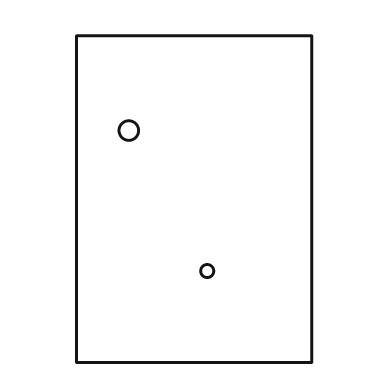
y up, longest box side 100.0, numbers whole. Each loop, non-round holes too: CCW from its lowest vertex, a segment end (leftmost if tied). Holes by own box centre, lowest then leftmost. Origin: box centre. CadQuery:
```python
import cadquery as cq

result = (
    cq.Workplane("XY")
    .moveTo(-36.0, -50.0)
    .lineTo(36.0, -50.0)
    .lineTo(36.0, 50.0)
    .lineTo(-36.0, 50.0)
    .close()
    .moveTo(4.0, -22.0)
    .circle(2.0)
    .moveTo(-20.0, 21.0)
    .circle(3.0)
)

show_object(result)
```